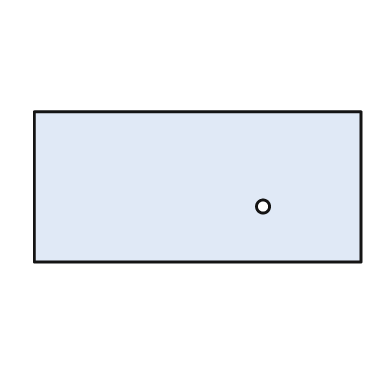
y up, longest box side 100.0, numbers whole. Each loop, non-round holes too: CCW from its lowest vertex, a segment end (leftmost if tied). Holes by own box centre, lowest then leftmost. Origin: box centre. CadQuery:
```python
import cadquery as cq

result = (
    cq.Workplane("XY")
    .moveTo(-50.0, -23.0)
    .lineTo(50.0, -23.0)
    .lineTo(50.0, 23.0)
    .lineTo(-50.0, 23.0)
    .close()
    .moveTo(20.0, -6.0)
    .circle(2.0)
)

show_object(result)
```